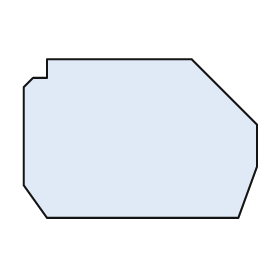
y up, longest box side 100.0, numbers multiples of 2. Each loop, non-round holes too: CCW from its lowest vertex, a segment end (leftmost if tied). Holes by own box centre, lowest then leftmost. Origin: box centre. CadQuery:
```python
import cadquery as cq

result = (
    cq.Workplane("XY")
    .moveTo(-40.0, -34.0)
    .lineTo(42.0, -34.0)
    .lineTo(50.0, -12.0)
    .lineTo(50.0, 6.0)
    .lineTo(22.0, 34.0)
    .lineTo(-40.0, 34.0)
    .lineTo(-40.0, 26.0)
    .lineTo(-46.0, 26.0)
    .lineTo(-50.0, 22.0)
    .lineTo(-50.0, -20.0)
    .close()
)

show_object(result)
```